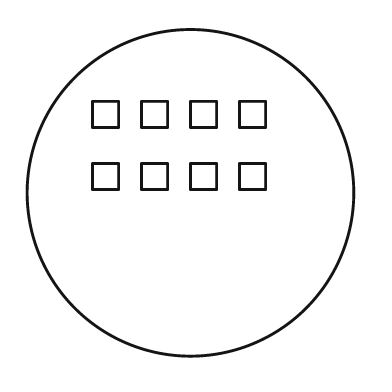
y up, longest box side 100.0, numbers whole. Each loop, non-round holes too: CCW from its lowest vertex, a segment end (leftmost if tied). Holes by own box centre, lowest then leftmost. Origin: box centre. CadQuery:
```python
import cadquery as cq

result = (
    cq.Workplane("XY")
    .moveTo(0.0, 0.0)
    .circle(50.0)
    .moveTo(-30.0, 1.0)
    .lineTo(-22.0, 1.0)
    .lineTo(-22.0, 9.0)
    .lineTo(-30.0, 9.0)
    .close()
    .moveTo(-15.0, 1.0)
    .lineTo(-7.0, 1.0)
    .lineTo(-7.0, 9.0)
    .lineTo(-15.0, 9.0)
    .close()
    .moveTo(0.0, 1.0)
    .lineTo(8.0, 1.0)
    .lineTo(8.0, 9.0)
    .lineTo(0.0, 9.0)
    .close()
    .moveTo(15.0, 1.0)
    .lineTo(23.0, 1.0)
    .lineTo(23.0, 9.0)
    .lineTo(15.0, 9.0)
    .close()
    .moveTo(-30.0, 20.0)
    .lineTo(-22.0, 20.0)
    .lineTo(-22.0, 28.0)
    .lineTo(-30.0, 28.0)
    .close()
    .moveTo(-15.0, 20.0)
    .lineTo(-7.0, 20.0)
    .lineTo(-7.0, 28.0)
    .lineTo(-15.0, 28.0)
    .close()
    .moveTo(0.0, 20.0)
    .lineTo(8.0, 20.0)
    .lineTo(8.0, 28.0)
    .lineTo(0.0, 28.0)
    .close()
    .moveTo(15.0, 20.0)
    .lineTo(23.0, 20.0)
    .lineTo(23.0, 28.0)
    .lineTo(15.0, 28.0)
    .close()
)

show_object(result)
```